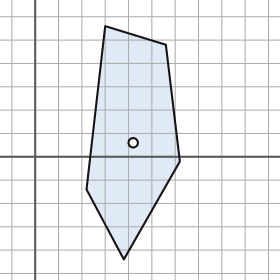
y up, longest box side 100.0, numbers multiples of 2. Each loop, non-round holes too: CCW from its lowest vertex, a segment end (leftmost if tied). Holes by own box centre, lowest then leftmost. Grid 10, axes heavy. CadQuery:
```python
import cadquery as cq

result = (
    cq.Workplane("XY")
    .moveTo(38.0, -44.0)
    .lineTo(62.0, -2.0)
    .lineTo(56.0, 48.0)
    .lineTo(30.0, 56.0)
    .lineTo(22.0, -14.0)
    .close()
    .moveTo(42.0, 6.0)
    .circle(2.0)
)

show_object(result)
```